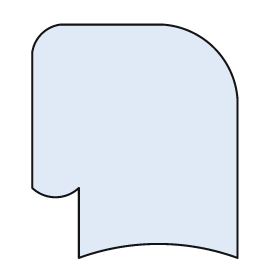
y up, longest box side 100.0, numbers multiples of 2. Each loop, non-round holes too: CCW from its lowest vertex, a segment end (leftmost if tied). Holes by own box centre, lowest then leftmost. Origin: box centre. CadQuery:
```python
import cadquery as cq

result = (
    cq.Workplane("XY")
    .moveTo(-24.0, -50.0)
    .threePointArc((10.0, -44.0), (44.0, -50.0))
    .lineTo(44.0, 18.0)
    .threePointArc((34.0, 40.0), (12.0, 50.0))
    .lineTo(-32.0, 50.0)
    .threePointArc((-40.0, 46.0), (-44.0, 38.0))
    .lineTo(-44.0, -20.0)
    .threePointArc((-34.0, -24.0), (-24.0, -20.0))
    .close()
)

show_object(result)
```